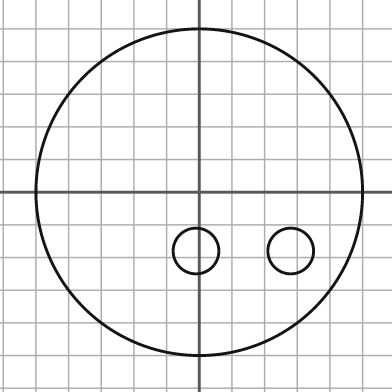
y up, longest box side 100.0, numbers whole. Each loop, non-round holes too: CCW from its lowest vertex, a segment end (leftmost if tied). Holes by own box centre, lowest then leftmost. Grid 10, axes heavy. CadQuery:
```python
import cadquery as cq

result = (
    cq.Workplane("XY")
    .moveTo(0.0, 0.0)
    .circle(50.0)
    .moveTo(-1.0, -18.0)
    .circle(7.0)
    .moveTo(28.0, -18.0)
    .circle(7.0)
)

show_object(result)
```